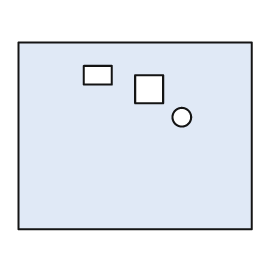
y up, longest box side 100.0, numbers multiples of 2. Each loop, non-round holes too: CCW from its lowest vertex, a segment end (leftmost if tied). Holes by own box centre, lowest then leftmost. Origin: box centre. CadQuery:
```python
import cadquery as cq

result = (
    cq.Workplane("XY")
    .moveTo(-50.0, -40.0)
    .lineTo(50.0, -40.0)
    .lineTo(50.0, 40.0)
    .lineTo(-50.0, 40.0)
    .close()
    .moveTo(20.0, 8.0)
    .circle(4.0)
    .moveTo(0.0, 14.0)
    .lineTo(12.0, 14.0)
    .lineTo(12.0, 26.0)
    .lineTo(0.0, 26.0)
    .close()
    .moveTo(-22.0, 22.0)
    .lineTo(-10.0, 22.0)
    .lineTo(-10.0, 30.0)
    .lineTo(-22.0, 30.0)
    .close()
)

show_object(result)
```